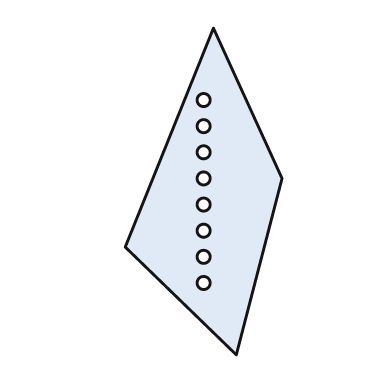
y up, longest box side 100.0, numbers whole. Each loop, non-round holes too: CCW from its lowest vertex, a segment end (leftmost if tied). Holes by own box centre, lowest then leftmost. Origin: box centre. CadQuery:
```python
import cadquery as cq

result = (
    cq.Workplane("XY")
    .moveTo(10.0, -50.0)
    .lineTo(24.0, 4.0)
    .lineTo(3.0, 50.0)
    .lineTo(-24.0, -17.0)
    .close()
    .moveTo(0.0, -28.0)
    .circle(2.0)
    .moveTo(0.0, -20.0)
    .circle(2.0)
    .moveTo(0.0, -12.0)
    .circle(2.0)
    .moveTo(0.0, -4.0)
    .circle(2.0)
    .moveTo(0.0, 4.0)
    .circle(2.0)
    .moveTo(0.0, 12.0)
    .circle(2.0)
    .moveTo(0.0, 20.0)
    .circle(2.0)
    .moveTo(0.0, 28.0)
    .circle(2.0)
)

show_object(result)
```